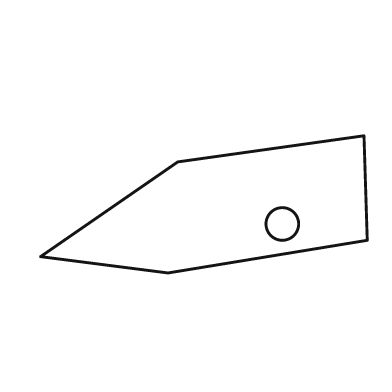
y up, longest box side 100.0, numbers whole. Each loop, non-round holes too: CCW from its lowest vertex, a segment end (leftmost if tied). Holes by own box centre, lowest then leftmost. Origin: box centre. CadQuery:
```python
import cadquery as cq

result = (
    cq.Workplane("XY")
    .moveTo(-11.0, -21.0)
    .lineTo(50.0, -11.0)
    .lineTo(49.0, 21.0)
    .lineTo(-8.0, 13.0)
    .lineTo(-50.0, -16.0)
    .close()
    .moveTo(24.0, -6.0)
    .circle(5.0)
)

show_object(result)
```